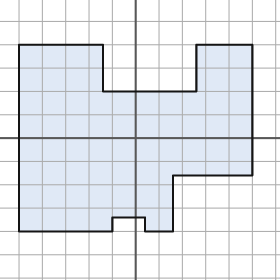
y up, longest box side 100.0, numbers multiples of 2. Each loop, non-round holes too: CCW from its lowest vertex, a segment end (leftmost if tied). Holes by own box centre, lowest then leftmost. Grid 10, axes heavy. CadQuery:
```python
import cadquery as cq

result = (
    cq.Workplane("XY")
    .moveTo(-50.0, -40.0)
    .lineTo(-10.0, -40.0)
    .lineTo(-10.0, -34.0)
    .lineTo(4.0, -34.0)
    .lineTo(4.0, -40.0)
    .lineTo(16.0, -40.0)
    .lineTo(16.0, -16.0)
    .lineTo(50.0, -16.0)
    .lineTo(50.0, 40.0)
    .lineTo(26.0, 40.0)
    .lineTo(26.0, 20.0)
    .lineTo(-14.0, 20.0)
    .lineTo(-14.0, 40.0)
    .lineTo(-50.0, 40.0)
    .close()
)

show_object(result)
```